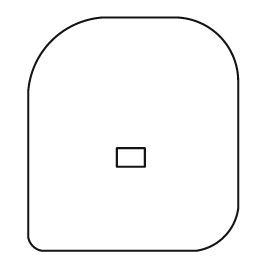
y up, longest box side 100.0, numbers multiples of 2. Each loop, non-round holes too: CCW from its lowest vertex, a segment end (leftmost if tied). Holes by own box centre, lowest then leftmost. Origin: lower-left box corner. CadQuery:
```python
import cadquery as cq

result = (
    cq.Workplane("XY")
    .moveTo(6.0, 0.0)
    .lineTo(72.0, 0.0)
    .threePointArc((84.0, 6.0), (90.0, 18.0))
    .lineTo(90.0, 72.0)
    .threePointArc((82.0, 92.0), (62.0, 100.0))
    .lineTo(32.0, 100.0)
    .threePointArc((10.0, 90.0), (0.0, 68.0))
    .lineTo(0.0, 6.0)
    .threePointArc((2.0, 2.0), (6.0, 0.0))
    .close()
    .moveTo(38.0, 36.0)
    .lineTo(50.0, 36.0)
    .lineTo(50.0, 44.0)
    .lineTo(38.0, 44.0)
    .close()
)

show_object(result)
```